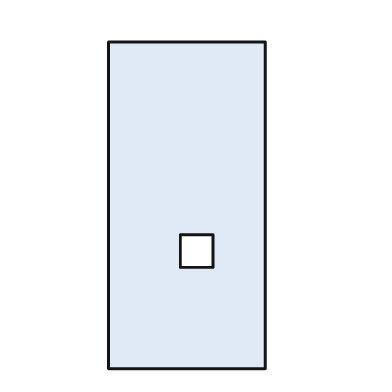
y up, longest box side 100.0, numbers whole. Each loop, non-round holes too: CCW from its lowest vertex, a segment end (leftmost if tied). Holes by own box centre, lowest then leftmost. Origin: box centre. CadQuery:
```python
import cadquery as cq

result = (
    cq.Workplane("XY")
    .moveTo(-24.0, -50.0)
    .lineTo(24.0, -50.0)
    .lineTo(24.0, 50.0)
    .lineTo(-24.0, 50.0)
    .close()
    .moveTo(-2.0, -19.0)
    .lineTo(8.0, -19.0)
    .lineTo(8.0, -9.0)
    .lineTo(-2.0, -9.0)
    .close()
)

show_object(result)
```